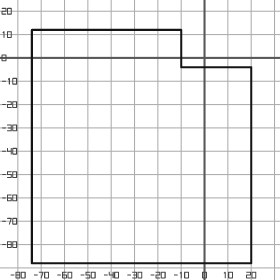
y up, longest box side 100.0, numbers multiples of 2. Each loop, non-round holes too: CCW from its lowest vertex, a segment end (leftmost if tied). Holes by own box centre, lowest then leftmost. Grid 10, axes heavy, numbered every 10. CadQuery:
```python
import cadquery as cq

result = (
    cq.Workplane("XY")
    .moveTo(-74.0, -88.0)
    .lineTo(20.0, -88.0)
    .lineTo(20.0, -4.0)
    .lineTo(-10.0, -4.0)
    .lineTo(-10.0, 12.0)
    .lineTo(-74.0, 12.0)
    .close()
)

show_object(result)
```